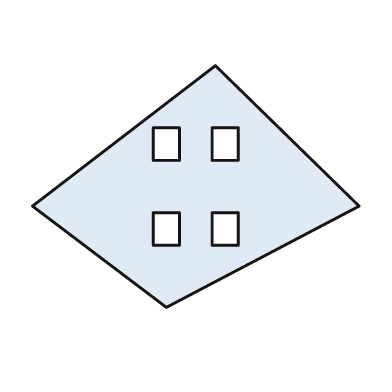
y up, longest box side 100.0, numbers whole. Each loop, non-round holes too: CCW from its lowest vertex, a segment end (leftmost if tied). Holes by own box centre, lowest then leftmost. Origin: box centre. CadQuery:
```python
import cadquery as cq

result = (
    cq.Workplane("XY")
    .moveTo(-9.0, -37.0)
    .lineTo(50.0, -6.0)
    .lineTo(6.0, 37.0)
    .lineTo(-50.0, -6.0)
    .close()
    .moveTo(-13.0, -18.0)
    .lineTo(-5.0, -18.0)
    .lineTo(-5.0, -8.0)
    .lineTo(-13.0, -8.0)
    .close()
    .moveTo(5.0, -18.0)
    .lineTo(13.0, -18.0)
    .lineTo(13.0, -8.0)
    .lineTo(5.0, -8.0)
    .close()
    .moveTo(-13.0, 8.0)
    .lineTo(-5.0, 8.0)
    .lineTo(-5.0, 18.0)
    .lineTo(-13.0, 18.0)
    .close()
    .moveTo(5.0, 8.0)
    .lineTo(13.0, 8.0)
    .lineTo(13.0, 18.0)
    .lineTo(5.0, 18.0)
    .close()
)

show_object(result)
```